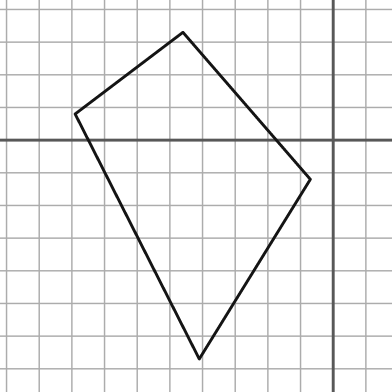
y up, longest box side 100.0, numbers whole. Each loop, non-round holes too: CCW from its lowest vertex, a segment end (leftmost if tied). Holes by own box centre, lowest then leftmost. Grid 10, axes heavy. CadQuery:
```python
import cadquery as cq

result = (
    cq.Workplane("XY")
    .moveTo(-41.0, -67.0)
    .lineTo(-7.0, -12.0)
    .lineTo(-46.0, 33.0)
    .lineTo(-79.0, 8.0)
    .close()
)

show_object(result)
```